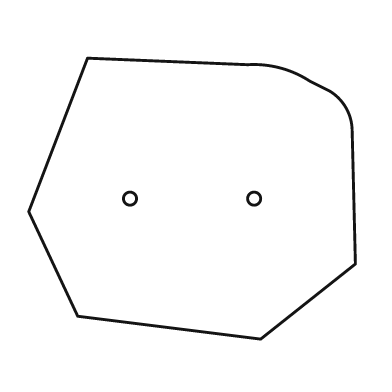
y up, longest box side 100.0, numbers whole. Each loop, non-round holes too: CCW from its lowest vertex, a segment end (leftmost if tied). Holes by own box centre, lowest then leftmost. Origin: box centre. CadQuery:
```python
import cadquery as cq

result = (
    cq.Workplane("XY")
    .moveTo(21.0, -43.0)
    .lineTo(50.0, -20.0)
    .lineTo(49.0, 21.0)
    .threePointArc((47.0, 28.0), (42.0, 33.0))
    .lineTo(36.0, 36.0)
    .threePointArc((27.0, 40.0), (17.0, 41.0))
    .lineTo(-32.0, 43.0)
    .lineTo(-50.0, -4.0)
    .lineTo(-35.0, -36.0)
    .close()
    .moveTo(-19.0, 0.0)
    .circle(2.0)
    .moveTo(19.0, 0.0)
    .circle(2.0)
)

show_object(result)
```